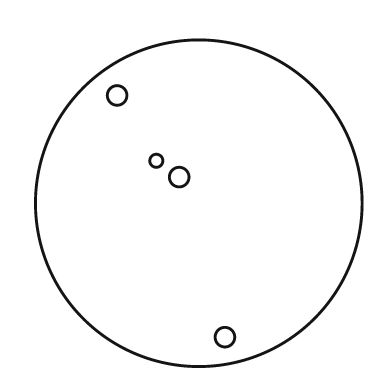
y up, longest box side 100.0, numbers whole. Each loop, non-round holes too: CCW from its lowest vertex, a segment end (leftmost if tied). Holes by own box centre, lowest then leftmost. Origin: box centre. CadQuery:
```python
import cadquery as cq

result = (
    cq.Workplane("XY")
    .moveTo(0.0, 0.0)
    .circle(50.0)
    .moveTo(8.0, -41.0)
    .circle(3.0)
    .moveTo(-6.0, 8.0)
    .circle(3.0)
    .moveTo(-13.0, 13.0)
    .circle(2.0)
    .moveTo(-25.0, 33.0)
    .circle(3.0)
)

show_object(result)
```